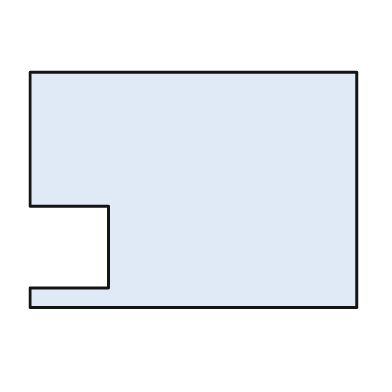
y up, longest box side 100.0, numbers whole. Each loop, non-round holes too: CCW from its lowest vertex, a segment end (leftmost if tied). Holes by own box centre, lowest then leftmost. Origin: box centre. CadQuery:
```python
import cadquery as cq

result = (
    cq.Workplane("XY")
    .moveTo(-50.0, -36.0)
    .lineTo(50.0, -36.0)
    .lineTo(50.0, 36.0)
    .lineTo(-50.0, 36.0)
    .lineTo(-50.0, -5.0)
    .lineTo(-26.0, -5.0)
    .lineTo(-26.0, -30.0)
    .lineTo(-50.0, -30.0)
    .close()
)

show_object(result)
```